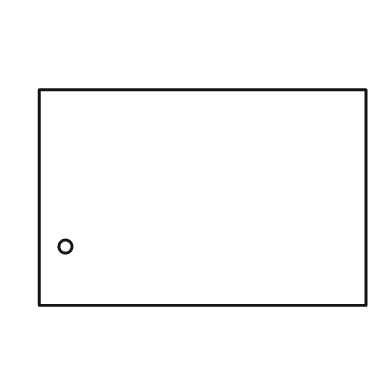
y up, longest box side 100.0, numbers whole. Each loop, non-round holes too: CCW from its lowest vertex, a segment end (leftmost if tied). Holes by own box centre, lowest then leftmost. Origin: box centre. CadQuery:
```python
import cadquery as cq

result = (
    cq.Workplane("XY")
    .moveTo(-50.0, -33.0)
    .lineTo(50.0, -33.0)
    .lineTo(50.0, 33.0)
    .lineTo(-50.0, 33.0)
    .close()
    .moveTo(-42.0, -15.0)
    .circle(2.0)
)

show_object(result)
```